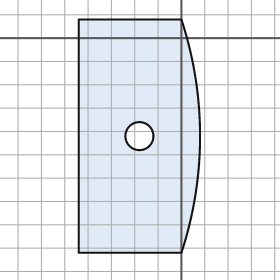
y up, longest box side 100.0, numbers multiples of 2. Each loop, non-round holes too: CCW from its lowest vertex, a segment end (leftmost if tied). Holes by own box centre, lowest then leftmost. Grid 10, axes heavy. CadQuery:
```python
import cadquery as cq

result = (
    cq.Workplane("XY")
    .moveTo(-44.0, -92.0)
    .lineTo(0.0, -92.0)
    .threePointArc((8.0, -42.0), (0.0, 8.0))
    .lineTo(-44.0, 8.0)
    .close()
    .moveTo(-18.0, -42.0)
    .circle(6.0)
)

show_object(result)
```